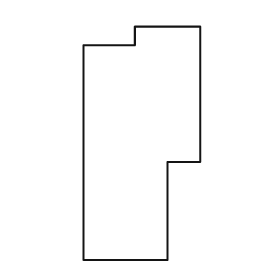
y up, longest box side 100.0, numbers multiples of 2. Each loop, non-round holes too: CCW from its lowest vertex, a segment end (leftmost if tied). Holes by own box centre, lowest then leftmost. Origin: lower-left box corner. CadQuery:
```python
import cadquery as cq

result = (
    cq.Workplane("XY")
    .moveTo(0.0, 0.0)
    .lineTo(36.0, 0.0)
    .lineTo(36.0, 42.0)
    .lineTo(50.0, 42.0)
    .lineTo(50.0, 100.0)
    .lineTo(22.0, 100.0)
    .lineTo(22.0, 92.0)
    .lineTo(0.0, 92.0)
    .close()
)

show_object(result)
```